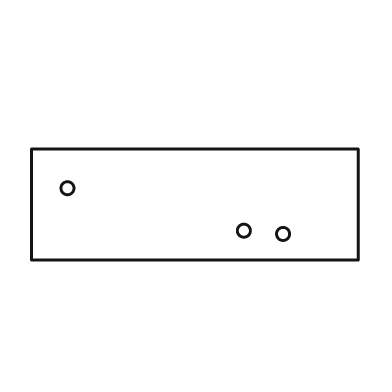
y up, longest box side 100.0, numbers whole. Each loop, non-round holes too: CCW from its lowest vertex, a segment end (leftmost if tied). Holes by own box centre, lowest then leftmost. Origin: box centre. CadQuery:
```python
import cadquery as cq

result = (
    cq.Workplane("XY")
    .moveTo(-50.0, -17.0)
    .lineTo(50.0, -17.0)
    .lineTo(50.0, 17.0)
    .lineTo(-50.0, 17.0)
    .close()
    .moveTo(27.0, -9.0)
    .circle(2.0)
    .moveTo(15.0, -8.0)
    .circle(2.0)
    .moveTo(-39.0, 5.0)
    .circle(2.0)
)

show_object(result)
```